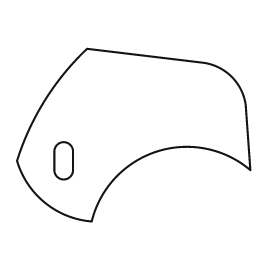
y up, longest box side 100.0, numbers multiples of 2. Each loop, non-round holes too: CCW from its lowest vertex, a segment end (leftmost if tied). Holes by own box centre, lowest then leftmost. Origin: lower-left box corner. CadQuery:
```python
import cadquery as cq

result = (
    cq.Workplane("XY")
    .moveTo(32.0, 0.0)
    .threePointArc((60.0, 30.0), (100.0, 22.0))
    .lineTo(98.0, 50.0)
    .threePointArc((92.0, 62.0), (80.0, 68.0))
    .lineTo(30.0, 74.0)
    .threePointArc((12.0, 52.0), (0.0, 26.0))
    .threePointArc((12.0, 8.0), (32.0, 0.0))
    .close()
    .moveTo(16.0, 22.0)
    .threePointArc((20.0, 18.0), (24.0, 22.0))
    .lineTo(24.0, 30.0)
    .threePointArc((20.0, 34.0), (16.0, 30.0))
    .close()
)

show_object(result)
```